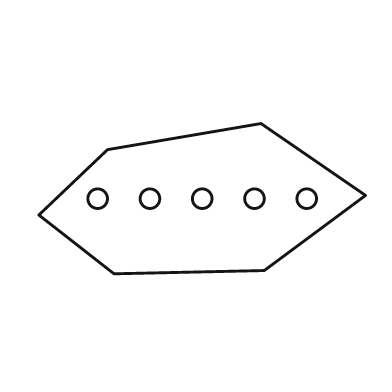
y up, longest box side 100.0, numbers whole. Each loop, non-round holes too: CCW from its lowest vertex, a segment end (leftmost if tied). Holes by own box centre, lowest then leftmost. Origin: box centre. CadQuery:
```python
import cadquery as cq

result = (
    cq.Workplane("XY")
    .moveTo(-27.0, -23.0)
    .lineTo(19.0, -22.0)
    .lineTo(50.0, 1.0)
    .lineTo(18.0, 23.0)
    .lineTo(-29.0, 15.0)
    .lineTo(-50.0, -5.0)
    .close()
    .moveTo(-32.0, 0.0)
    .circle(3.0)
    .moveTo(-16.0, 0.0)
    .circle(3.0)
    .moveTo(0.0, 0.0)
    .circle(3.0)
    .moveTo(16.0, 0.0)
    .circle(3.0)
    .moveTo(32.0, 0.0)
    .circle(3.0)
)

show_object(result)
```